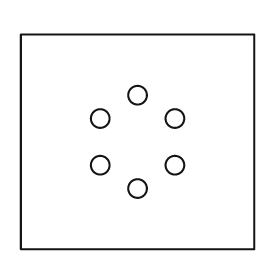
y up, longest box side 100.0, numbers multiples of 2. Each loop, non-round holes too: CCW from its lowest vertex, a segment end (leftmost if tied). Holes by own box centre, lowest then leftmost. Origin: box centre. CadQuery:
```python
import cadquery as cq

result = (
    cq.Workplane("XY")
    .moveTo(-50.0, -46.0)
    .lineTo(50.0, -46.0)
    .lineTo(50.0, 46.0)
    .lineTo(-50.0, 46.0)
    .close()
    .moveTo(0.0, -20.0)
    .circle(4.0)
    .moveTo(-16.0, -10.0)
    .circle(4.0)
    .moveTo(16.0, -10.0)
    .circle(4.0)
    .moveTo(-16.0, 10.0)
    .circle(4.0)
    .moveTo(16.0, 10.0)
    .circle(4.0)
    .moveTo(0.0, 20.0)
    .circle(4.0)
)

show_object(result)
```